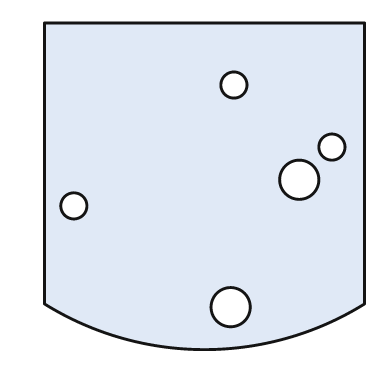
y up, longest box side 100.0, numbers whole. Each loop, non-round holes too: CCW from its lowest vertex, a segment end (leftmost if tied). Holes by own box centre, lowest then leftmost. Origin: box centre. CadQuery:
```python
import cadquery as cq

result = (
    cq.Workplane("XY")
    .moveTo(-49.0, -36.0)
    .threePointArc((0.0, -50.0), (49.0, -36.0))
    .lineTo(49.0, 50.0)
    .lineTo(-49.0, 50.0)
    .close()
    .moveTo(8.0, -37.0)
    .circle(6.0)
    .moveTo(-40.0, -6.0)
    .circle(4.0)
    .moveTo(29.0, 2.0)
    .circle(6.0)
    .moveTo(39.0, 12.0)
    .circle(4.0)
    .moveTo(9.0, 31.0)
    .circle(4.0)
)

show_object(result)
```